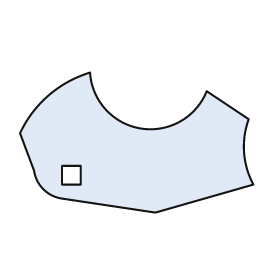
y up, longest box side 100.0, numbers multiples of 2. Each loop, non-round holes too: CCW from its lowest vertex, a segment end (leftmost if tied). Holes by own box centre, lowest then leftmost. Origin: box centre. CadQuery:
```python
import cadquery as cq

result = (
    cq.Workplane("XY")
    .moveTo(8.0, -30.0)
    .lineTo(50.0, -18.0)
    .threePointArc((46.0, -4.0), (48.0, 10.0))
    .lineTo(30.0, 22.0)
    .threePointArc((2.0, 6.0), (-20.0, 30.0))
    .threePointArc((-38.0, 20.0), (-50.0, 4.0))
    .lineTo(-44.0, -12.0)
    .threePointArc((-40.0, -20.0), (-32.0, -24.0))
    .close()
    .moveTo(-32.0, -18.0)
    .lineTo(-24.0, -18.0)
    .lineTo(-24.0, -10.0)
    .lineTo(-32.0, -10.0)
    .close()
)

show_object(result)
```